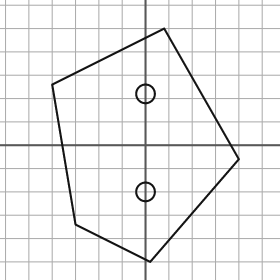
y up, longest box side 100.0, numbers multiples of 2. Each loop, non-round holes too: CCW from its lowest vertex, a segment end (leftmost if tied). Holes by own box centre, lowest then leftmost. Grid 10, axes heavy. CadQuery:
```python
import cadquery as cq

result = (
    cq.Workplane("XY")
    .moveTo(2.0, -50.0)
    .lineTo(40.0, -6.0)
    .lineTo(8.0, 50.0)
    .lineTo(-40.0, 26.0)
    .lineTo(-30.0, -34.0)
    .close()
    .moveTo(0.0, -20.0)
    .circle(4.0)
    .moveTo(0.0, 22.0)
    .circle(4.0)
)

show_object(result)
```